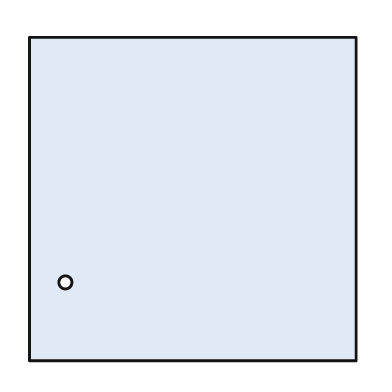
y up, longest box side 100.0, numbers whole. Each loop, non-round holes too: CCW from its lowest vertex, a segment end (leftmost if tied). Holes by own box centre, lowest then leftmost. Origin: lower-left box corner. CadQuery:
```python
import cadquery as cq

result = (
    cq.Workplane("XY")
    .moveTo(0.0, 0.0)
    .lineTo(100.0, 0.0)
    .lineTo(100.0, 99.0)
    .lineTo(0.0, 99.0)
    .close()
    .moveTo(11.0, 24.0)
    .circle(2.0)
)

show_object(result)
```